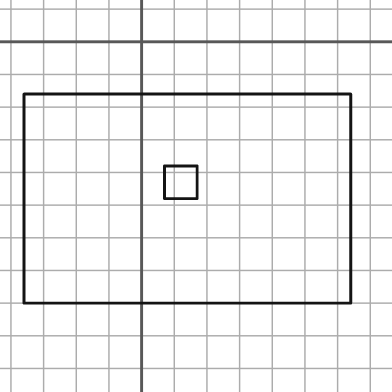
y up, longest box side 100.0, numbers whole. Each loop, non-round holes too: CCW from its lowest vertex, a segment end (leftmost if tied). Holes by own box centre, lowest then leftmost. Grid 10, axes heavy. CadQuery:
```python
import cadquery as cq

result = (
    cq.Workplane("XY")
    .moveTo(-36.0, -80.0)
    .lineTo(64.0, -80.0)
    .lineTo(64.0, -16.0)
    .lineTo(-36.0, -16.0)
    .close()
    .moveTo(7.0, -48.0)
    .lineTo(17.0, -48.0)
    .lineTo(17.0, -38.0)
    .lineTo(7.0, -38.0)
    .close()
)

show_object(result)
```